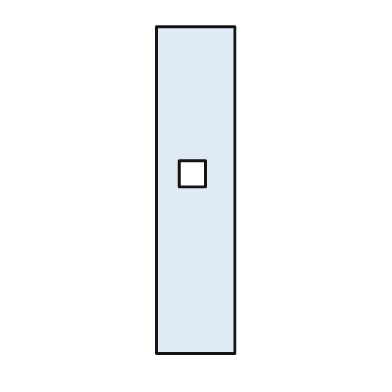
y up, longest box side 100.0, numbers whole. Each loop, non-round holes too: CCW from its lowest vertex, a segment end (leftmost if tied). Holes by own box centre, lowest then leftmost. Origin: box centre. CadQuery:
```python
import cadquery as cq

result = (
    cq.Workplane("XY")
    .moveTo(-12.0, -50.0)
    .lineTo(12.0, -50.0)
    .lineTo(12.0, 50.0)
    .lineTo(-12.0, 50.0)
    .close()
    .moveTo(-5.0, 1.0)
    .lineTo(3.0, 1.0)
    .lineTo(3.0, 9.0)
    .lineTo(-5.0, 9.0)
    .close()
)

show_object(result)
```